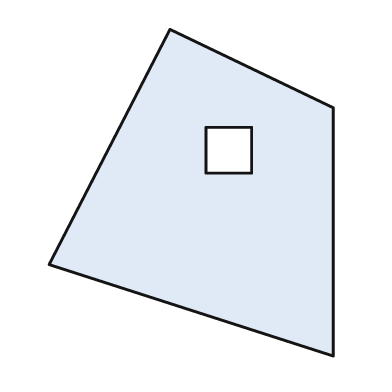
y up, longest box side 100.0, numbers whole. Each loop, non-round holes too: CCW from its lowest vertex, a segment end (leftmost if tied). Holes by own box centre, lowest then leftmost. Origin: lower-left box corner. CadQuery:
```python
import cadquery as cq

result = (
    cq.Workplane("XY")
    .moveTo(87.0, 0.0)
    .lineTo(87.0, 76.0)
    .lineTo(37.0, 100.0)
    .lineTo(0.0, 28.0)
    .close()
    .moveTo(48.0, 56.0)
    .lineTo(62.0, 56.0)
    .lineTo(62.0, 70.0)
    .lineTo(48.0, 70.0)
    .close()
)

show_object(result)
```